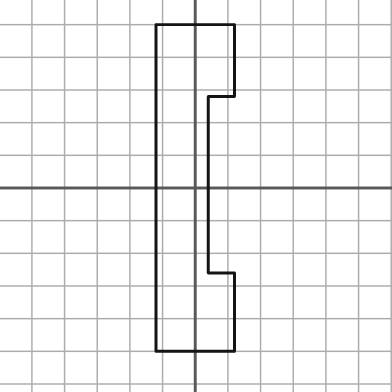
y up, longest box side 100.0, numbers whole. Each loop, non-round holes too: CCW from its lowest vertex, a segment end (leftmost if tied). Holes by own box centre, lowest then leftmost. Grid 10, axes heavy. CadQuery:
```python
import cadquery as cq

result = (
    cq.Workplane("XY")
    .moveTo(-12.0, -50.0)
    .lineTo(12.0, -50.0)
    .lineTo(12.0, -26.0)
    .lineTo(4.0, -26.0)
    .lineTo(4.0, 28.0)
    .lineTo(12.0, 28.0)
    .lineTo(12.0, 50.0)
    .lineTo(-12.0, 50.0)
    .close()
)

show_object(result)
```